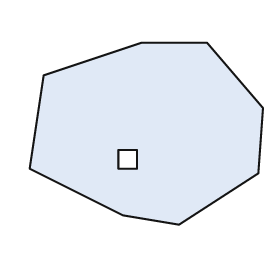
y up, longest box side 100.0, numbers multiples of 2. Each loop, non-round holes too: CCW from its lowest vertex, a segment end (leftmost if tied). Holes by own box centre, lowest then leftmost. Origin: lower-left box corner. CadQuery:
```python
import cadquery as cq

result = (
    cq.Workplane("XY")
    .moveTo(64.0, 0.0)
    .lineTo(98.0, 22.0)
    .lineTo(100.0, 50.0)
    .lineTo(76.0, 78.0)
    .lineTo(48.0, 78.0)
    .lineTo(6.0, 64.0)
    .lineTo(0.0, 24.0)
    .lineTo(40.0, 4.0)
    .close()
    .moveTo(38.0, 24.0)
    .lineTo(46.0, 24.0)
    .lineTo(46.0, 32.0)
    .lineTo(38.0, 32.0)
    .close()
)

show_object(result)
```